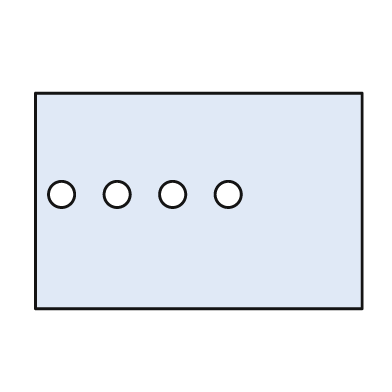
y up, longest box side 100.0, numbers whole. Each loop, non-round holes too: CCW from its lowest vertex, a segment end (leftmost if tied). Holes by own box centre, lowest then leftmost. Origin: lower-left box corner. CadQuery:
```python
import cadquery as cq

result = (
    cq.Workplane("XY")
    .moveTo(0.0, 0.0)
    .lineTo(100.0, 0.0)
    .lineTo(100.0, 66.0)
    .lineTo(0.0, 66.0)
    .close()
    .moveTo(8.0, 35.0)
    .circle(4.0)
    .moveTo(25.0, 35.0)
    .circle(4.0)
    .moveTo(42.0, 35.0)
    .circle(4.0)
    .moveTo(59.0, 35.0)
    .circle(4.0)
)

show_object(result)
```